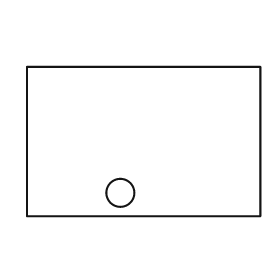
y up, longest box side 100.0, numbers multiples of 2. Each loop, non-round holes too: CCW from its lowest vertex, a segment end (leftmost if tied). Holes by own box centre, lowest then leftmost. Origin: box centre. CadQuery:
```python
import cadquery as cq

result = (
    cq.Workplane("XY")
    .moveTo(-50.0, -32.0)
    .lineTo(50.0, -32.0)
    .lineTo(50.0, 32.0)
    .lineTo(-50.0, 32.0)
    .close()
    .moveTo(-10.0, -22.0)
    .circle(6.0)
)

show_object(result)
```